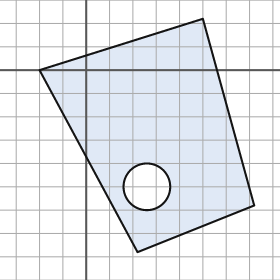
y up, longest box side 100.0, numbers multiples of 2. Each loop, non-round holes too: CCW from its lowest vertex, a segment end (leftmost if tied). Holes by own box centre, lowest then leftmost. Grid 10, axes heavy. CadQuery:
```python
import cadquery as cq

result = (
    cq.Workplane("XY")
    .moveTo(22.0, -78.0)
    .lineTo(72.0, -58.0)
    .lineTo(50.0, 22.0)
    .lineTo(-20.0, 0.0)
    .close()
    .moveTo(26.0, -50.0)
    .circle(10.0)
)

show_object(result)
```